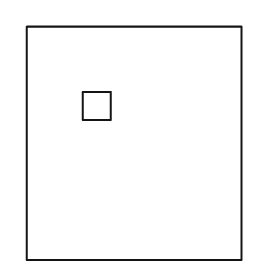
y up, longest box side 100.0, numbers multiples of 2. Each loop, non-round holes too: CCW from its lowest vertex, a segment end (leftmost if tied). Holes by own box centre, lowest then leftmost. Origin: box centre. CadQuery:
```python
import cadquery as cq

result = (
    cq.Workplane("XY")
    .moveTo(-46.0, -50.0)
    .lineTo(46.0, -50.0)
    .lineTo(46.0, 50.0)
    .lineTo(-46.0, 50.0)
    .close()
    .moveTo(-22.0, 10.0)
    .lineTo(-10.0, 10.0)
    .lineTo(-10.0, 22.0)
    .lineTo(-22.0, 22.0)
    .close()
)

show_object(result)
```